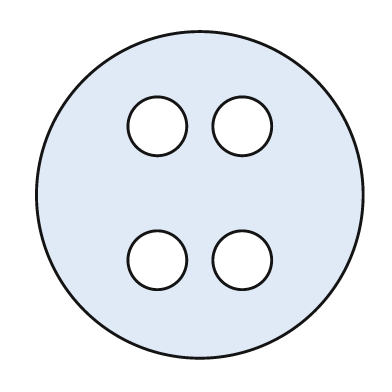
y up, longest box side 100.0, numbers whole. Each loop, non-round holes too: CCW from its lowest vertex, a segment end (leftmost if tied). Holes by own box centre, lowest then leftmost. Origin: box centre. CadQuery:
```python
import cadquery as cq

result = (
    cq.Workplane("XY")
    .moveTo(0.0, 0.0)
    .circle(50.0)
    .moveTo(-13.0, -20.0)
    .circle(9.0)
    .moveTo(13.0, -20.0)
    .circle(9.0)
    .moveTo(-13.0, 21.0)
    .circle(9.0)
    .moveTo(13.0, 21.0)
    .circle(9.0)
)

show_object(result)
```